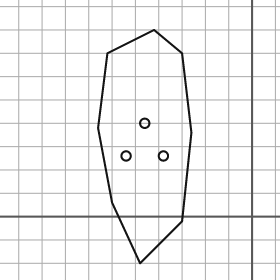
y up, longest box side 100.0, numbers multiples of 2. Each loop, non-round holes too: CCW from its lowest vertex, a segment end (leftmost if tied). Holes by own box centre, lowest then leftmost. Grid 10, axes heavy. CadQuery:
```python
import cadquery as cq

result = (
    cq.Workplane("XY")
    .moveTo(-48.0, -20.0)
    .lineTo(-30.0, -2.0)
    .lineTo(-26.0, 36.0)
    .lineTo(-30.0, 70.0)
    .lineTo(-42.0, 80.0)
    .lineTo(-62.0, 70.0)
    .lineTo(-66.0, 38.0)
    .lineTo(-60.0, 6.0)
    .close()
    .moveTo(-54.0, 26.0)
    .circle(2.0)
    .moveTo(-38.0, 26.0)
    .circle(2.0)
    .moveTo(-46.0, 40.0)
    .circle(2.0)
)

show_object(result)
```